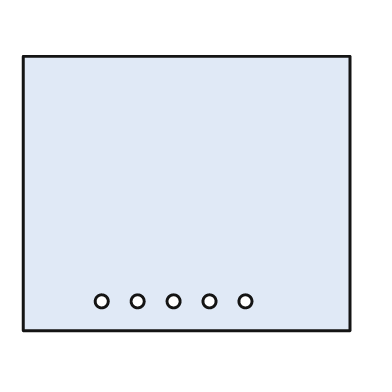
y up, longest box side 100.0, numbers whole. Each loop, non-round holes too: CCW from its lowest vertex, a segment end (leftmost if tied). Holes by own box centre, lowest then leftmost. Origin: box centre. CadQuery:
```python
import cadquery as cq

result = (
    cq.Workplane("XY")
    .moveTo(-50.0, -42.0)
    .lineTo(50.0, -42.0)
    .lineTo(50.0, 42.0)
    .lineTo(-50.0, 42.0)
    .close()
    .moveTo(-26.0, -33.0)
    .circle(2.0)
    .moveTo(-15.0, -33.0)
    .circle(2.0)
    .moveTo(-4.0, -33.0)
    .circle(2.0)
    .moveTo(7.0, -33.0)
    .circle(2.0)
    .moveTo(18.0, -33.0)
    .circle(2.0)
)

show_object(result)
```